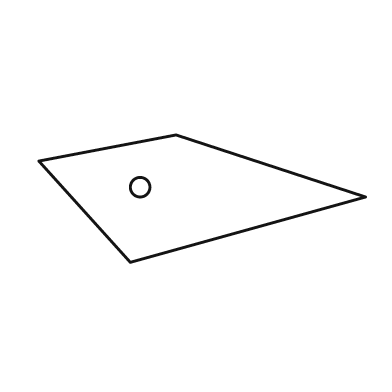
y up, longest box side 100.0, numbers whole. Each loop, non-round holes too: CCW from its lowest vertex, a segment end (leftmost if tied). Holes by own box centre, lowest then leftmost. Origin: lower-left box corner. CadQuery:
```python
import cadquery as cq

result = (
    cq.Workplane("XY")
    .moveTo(28.0, 0.0)
    .lineTo(100.0, 20.0)
    .lineTo(42.0, 39.0)
    .lineTo(0.0, 31.0)
    .close()
    .moveTo(31.0, 23.0)
    .circle(3.0)
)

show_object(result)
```